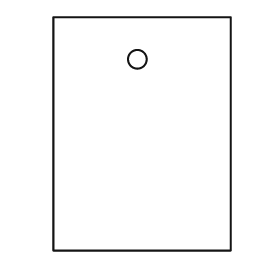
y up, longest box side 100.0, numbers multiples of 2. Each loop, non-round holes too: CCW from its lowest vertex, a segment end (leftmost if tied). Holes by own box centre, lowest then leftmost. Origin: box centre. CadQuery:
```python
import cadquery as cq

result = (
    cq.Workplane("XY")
    .moveTo(-38.0, -50.0)
    .lineTo(38.0, -50.0)
    .lineTo(38.0, 50.0)
    .lineTo(-38.0, 50.0)
    .close()
    .moveTo(-2.0, 32.0)
    .circle(4.0)
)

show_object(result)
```